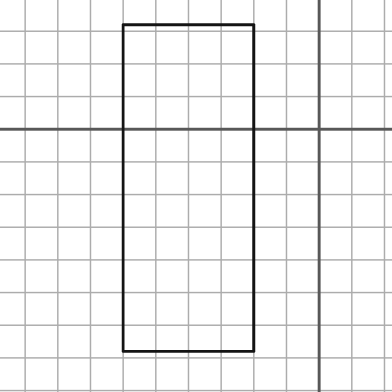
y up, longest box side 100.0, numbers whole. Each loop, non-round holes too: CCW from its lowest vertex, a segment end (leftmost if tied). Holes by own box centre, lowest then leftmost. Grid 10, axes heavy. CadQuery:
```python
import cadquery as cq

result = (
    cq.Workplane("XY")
    .moveTo(-60.0, -68.0)
    .lineTo(-20.0, -68.0)
    .lineTo(-20.0, 32.0)
    .lineTo(-60.0, 32.0)
    .close()
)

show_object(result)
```